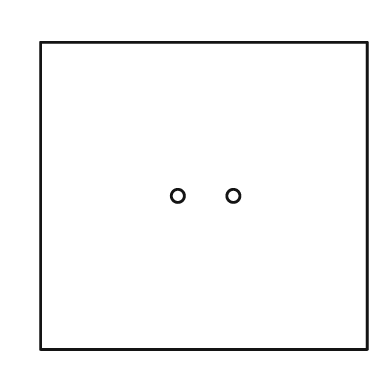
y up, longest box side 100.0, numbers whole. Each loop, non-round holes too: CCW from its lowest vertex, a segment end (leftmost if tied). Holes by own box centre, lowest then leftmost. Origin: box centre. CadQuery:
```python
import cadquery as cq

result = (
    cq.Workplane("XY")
    .moveTo(-50.0, -47.0)
    .lineTo(50.0, -47.0)
    .lineTo(50.0, 47.0)
    .lineTo(-50.0, 47.0)
    .close()
    .moveTo(-8.0, 0.0)
    .circle(2.0)
    .moveTo(9.0, 0.0)
    .circle(2.0)
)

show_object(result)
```